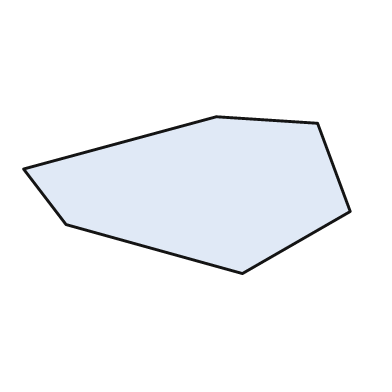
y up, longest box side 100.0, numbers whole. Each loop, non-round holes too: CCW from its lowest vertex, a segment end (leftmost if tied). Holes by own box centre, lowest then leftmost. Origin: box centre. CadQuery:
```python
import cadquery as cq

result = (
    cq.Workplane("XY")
    .moveTo(17.0, -24.0)
    .lineTo(50.0, -5.0)
    .lineTo(40.0, 22.0)
    .lineTo(9.0, 24.0)
    .lineTo(-50.0, 8.0)
    .lineTo(-37.0, -9.0)
    .close()
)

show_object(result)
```